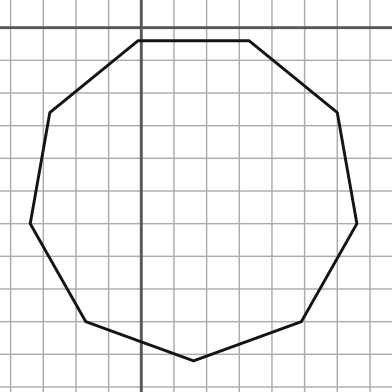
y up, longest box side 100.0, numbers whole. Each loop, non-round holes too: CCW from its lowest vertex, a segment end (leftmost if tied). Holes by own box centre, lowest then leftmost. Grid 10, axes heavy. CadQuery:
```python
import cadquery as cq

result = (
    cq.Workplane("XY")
    .moveTo(16.0, -102.0)
    .lineTo(49.0, -90.0)
    .lineTo(66.0, -60.0)
    .lineTo(60.0, -26.0)
    .lineTo(33.0, -4.0)
    .lineTo(-1.0, -4.0)
    .lineTo(-28.0, -26.0)
    .lineTo(-34.0, -60.0)
    .lineTo(-17.0, -90.0)
    .close()
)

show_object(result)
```